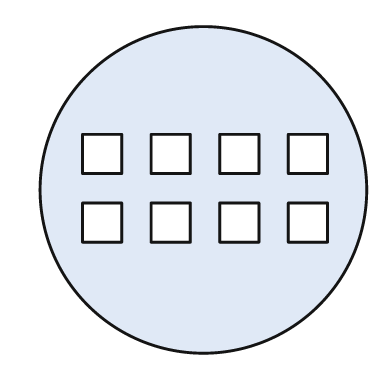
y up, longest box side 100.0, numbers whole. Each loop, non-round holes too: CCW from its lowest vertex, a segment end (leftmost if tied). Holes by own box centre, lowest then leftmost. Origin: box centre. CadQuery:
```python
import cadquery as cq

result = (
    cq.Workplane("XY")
    .moveTo(0.0, 0.0)
    .circle(50.0)
    .moveTo(-37.0, -16.0)
    .lineTo(-25.0, -16.0)
    .lineTo(-25.0, -4.0)
    .lineTo(-37.0, -4.0)
    .close()
    .moveTo(-16.0, -16.0)
    .lineTo(-4.0, -16.0)
    .lineTo(-4.0, -4.0)
    .lineTo(-16.0, -4.0)
    .close()
    .moveTo(5.0, -16.0)
    .lineTo(17.0, -16.0)
    .lineTo(17.0, -4.0)
    .lineTo(5.0, -4.0)
    .close()
    .moveTo(26.0, -16.0)
    .lineTo(38.0, -16.0)
    .lineTo(38.0, -4.0)
    .lineTo(26.0, -4.0)
    .close()
    .moveTo(-37.0, 5.0)
    .lineTo(-25.0, 5.0)
    .lineTo(-25.0, 17.0)
    .lineTo(-37.0, 17.0)
    .close()
    .moveTo(-16.0, 5.0)
    .lineTo(-4.0, 5.0)
    .lineTo(-4.0, 17.0)
    .lineTo(-16.0, 17.0)
    .close()
    .moveTo(5.0, 5.0)
    .lineTo(17.0, 5.0)
    .lineTo(17.0, 17.0)
    .lineTo(5.0, 17.0)
    .close()
    .moveTo(26.0, 5.0)
    .lineTo(38.0, 5.0)
    .lineTo(38.0, 17.0)
    .lineTo(26.0, 17.0)
    .close()
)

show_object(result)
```